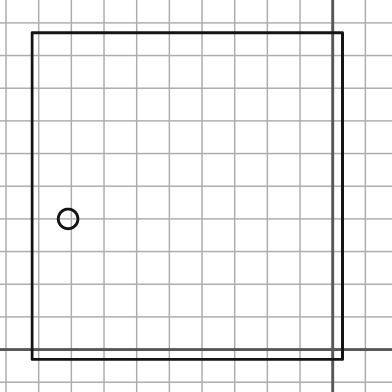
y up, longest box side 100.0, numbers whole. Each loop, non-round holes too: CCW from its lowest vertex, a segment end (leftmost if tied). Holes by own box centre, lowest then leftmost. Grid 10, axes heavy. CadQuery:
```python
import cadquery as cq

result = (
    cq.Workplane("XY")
    .moveTo(-92.0, -3.0)
    .lineTo(3.0, -3.0)
    .lineTo(3.0, 97.0)
    .lineTo(-92.0, 97.0)
    .close()
    .moveTo(-81.0, 40.0)
    .circle(3.0)
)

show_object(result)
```